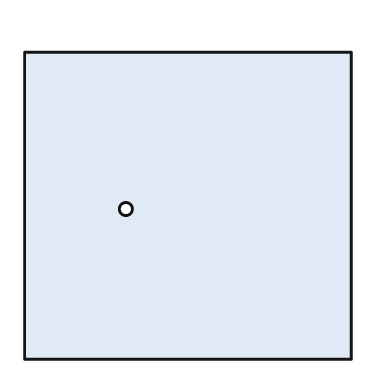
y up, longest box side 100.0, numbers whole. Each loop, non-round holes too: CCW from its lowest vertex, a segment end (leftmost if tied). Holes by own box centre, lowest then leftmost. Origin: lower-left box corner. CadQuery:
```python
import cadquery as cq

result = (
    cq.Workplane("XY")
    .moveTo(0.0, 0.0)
    .lineTo(100.0, 0.0)
    .lineTo(100.0, 94.0)
    .lineTo(0.0, 94.0)
    .close()
    .moveTo(31.0, 46.0)
    .circle(2.0)
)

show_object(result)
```